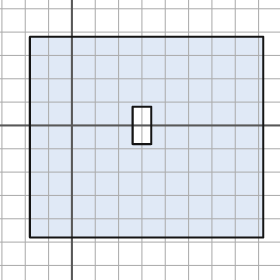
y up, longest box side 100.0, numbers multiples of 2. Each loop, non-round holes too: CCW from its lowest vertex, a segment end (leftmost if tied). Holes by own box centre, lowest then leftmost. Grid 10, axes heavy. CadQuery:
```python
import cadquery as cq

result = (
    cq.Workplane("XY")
    .moveTo(-18.0, -48.0)
    .lineTo(82.0, -48.0)
    .lineTo(82.0, 38.0)
    .lineTo(-18.0, 38.0)
    .close()
    .moveTo(26.0, -8.0)
    .lineTo(34.0, -8.0)
    .lineTo(34.0, 8.0)
    .lineTo(26.0, 8.0)
    .close()
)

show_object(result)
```